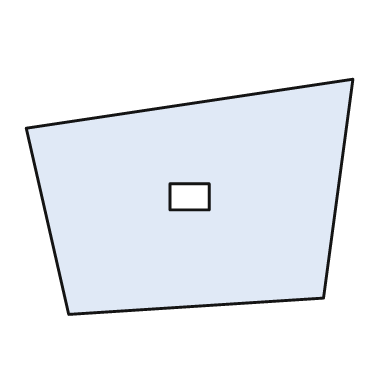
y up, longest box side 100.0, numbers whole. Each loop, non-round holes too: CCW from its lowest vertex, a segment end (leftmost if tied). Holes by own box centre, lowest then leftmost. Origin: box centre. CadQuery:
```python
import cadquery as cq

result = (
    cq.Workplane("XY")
    .moveTo(-37.0, -36.0)
    .lineTo(41.0, -31.0)
    .lineTo(50.0, 36.0)
    .lineTo(-50.0, 21.0)
    .close()
    .moveTo(-6.0, -4.0)
    .lineTo(6.0, -4.0)
    .lineTo(6.0, 4.0)
    .lineTo(-6.0, 4.0)
    .close()
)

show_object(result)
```